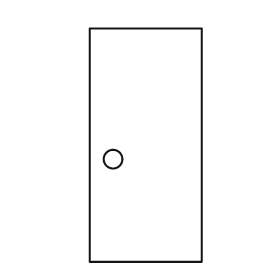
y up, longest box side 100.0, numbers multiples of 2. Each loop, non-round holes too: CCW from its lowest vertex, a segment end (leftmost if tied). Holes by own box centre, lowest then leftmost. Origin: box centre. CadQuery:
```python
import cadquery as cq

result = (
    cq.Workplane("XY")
    .moveTo(-24.0, -50.0)
    .lineTo(24.0, -50.0)
    .lineTo(24.0, 50.0)
    .lineTo(-24.0, 50.0)
    .close()
    .moveTo(-14.0, -6.0)
    .circle(4.0)
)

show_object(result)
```